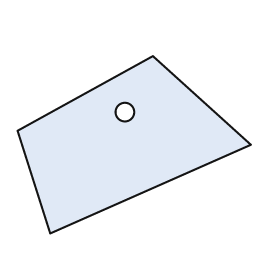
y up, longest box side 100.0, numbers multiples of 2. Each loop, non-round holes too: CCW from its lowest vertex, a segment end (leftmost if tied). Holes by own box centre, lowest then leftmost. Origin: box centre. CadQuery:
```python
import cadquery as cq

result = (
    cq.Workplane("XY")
    .moveTo(-36.0, -38.0)
    .lineTo(50.0, 0.0)
    .lineTo(8.0, 38.0)
    .lineTo(-50.0, 6.0)
    .close()
    .moveTo(-4.0, 14.0)
    .circle(4.0)
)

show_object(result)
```